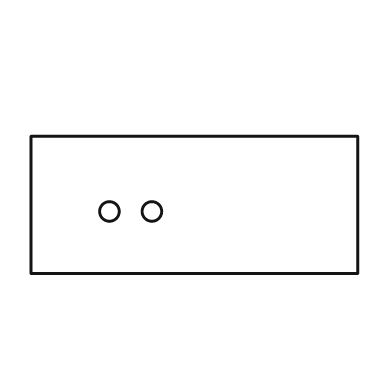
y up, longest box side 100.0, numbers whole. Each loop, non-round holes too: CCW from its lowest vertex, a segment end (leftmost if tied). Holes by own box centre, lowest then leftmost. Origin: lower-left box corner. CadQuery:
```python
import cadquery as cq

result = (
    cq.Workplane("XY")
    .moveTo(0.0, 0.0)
    .lineTo(100.0, 0.0)
    .lineTo(100.0, 42.0)
    .lineTo(0.0, 42.0)
    .close()
    .moveTo(24.0, 19.0)
    .circle(3.0)
    .moveTo(37.0, 19.0)
    .circle(3.0)
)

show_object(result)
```